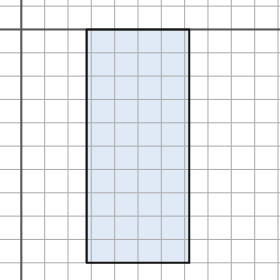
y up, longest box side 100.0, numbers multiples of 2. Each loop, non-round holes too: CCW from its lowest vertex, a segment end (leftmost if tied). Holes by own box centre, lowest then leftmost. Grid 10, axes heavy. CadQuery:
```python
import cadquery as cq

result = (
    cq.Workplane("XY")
    .moveTo(28.0, -100.0)
    .lineTo(72.0, -100.0)
    .lineTo(72.0, 0.0)
    .lineTo(28.0, 0.0)
    .close()
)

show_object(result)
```